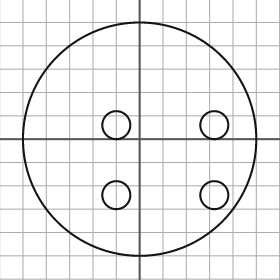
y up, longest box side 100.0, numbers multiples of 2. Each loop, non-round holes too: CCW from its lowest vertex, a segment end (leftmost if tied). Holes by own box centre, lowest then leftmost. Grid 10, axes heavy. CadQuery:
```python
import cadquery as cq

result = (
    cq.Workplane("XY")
    .moveTo(0.0, 0.0)
    .circle(50.0)
    .moveTo(-10.0, -24.0)
    .circle(6.0)
    .moveTo(32.0, -24.0)
    .circle(6.0)
    .moveTo(-10.0, 6.0)
    .circle(6.0)
    .moveTo(32.0, 6.0)
    .circle(6.0)
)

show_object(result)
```